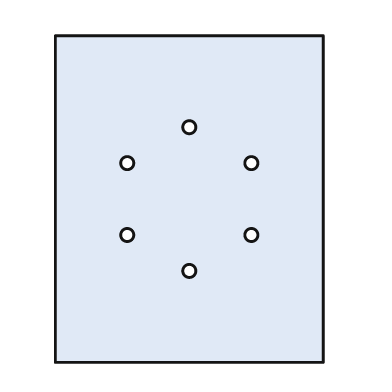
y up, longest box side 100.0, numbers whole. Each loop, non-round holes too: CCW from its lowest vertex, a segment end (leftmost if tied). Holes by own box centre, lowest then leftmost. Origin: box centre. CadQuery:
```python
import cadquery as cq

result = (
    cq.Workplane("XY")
    .moveTo(-41.0, -50.0)
    .lineTo(41.0, -50.0)
    .lineTo(41.0, 50.0)
    .lineTo(-41.0, 50.0)
    .close()
    .moveTo(0.0, -22.0)
    .circle(2.0)
    .moveTo(-19.0, -11.0)
    .circle(2.0)
    .moveTo(19.0, -11.0)
    .circle(2.0)
    .moveTo(-19.0, 11.0)
    .circle(2.0)
    .moveTo(19.0, 11.0)
    .circle(2.0)
    .moveTo(0.0, 22.0)
    .circle(2.0)
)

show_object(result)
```